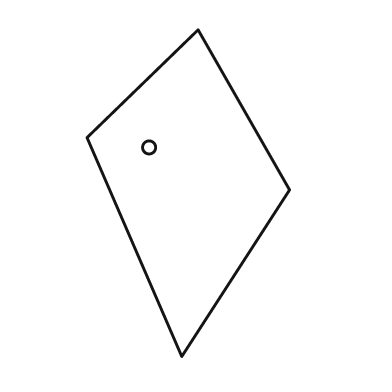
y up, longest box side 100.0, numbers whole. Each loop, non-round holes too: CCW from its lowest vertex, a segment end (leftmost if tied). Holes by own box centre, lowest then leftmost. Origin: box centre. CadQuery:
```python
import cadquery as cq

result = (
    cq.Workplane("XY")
    .moveTo(-2.0, -50.0)
    .lineTo(31.0, 1.0)
    .lineTo(3.0, 50.0)
    .lineTo(-31.0, 17.0)
    .close()
    .moveTo(-12.0, 14.0)
    .circle(2.0)
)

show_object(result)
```